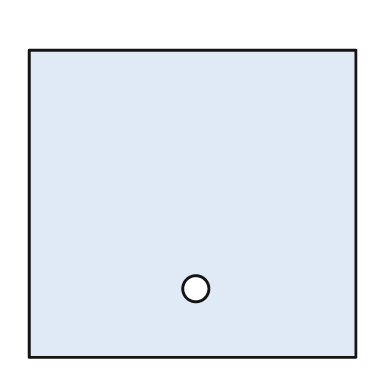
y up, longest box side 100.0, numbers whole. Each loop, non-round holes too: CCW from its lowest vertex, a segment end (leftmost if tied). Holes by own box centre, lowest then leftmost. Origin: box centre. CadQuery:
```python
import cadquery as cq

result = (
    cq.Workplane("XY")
    .moveTo(-50.0, -47.0)
    .lineTo(50.0, -47.0)
    .lineTo(50.0, 47.0)
    .lineTo(-50.0, 47.0)
    .close()
    .moveTo(1.0, -26.0)
    .circle(4.0)
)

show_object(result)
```